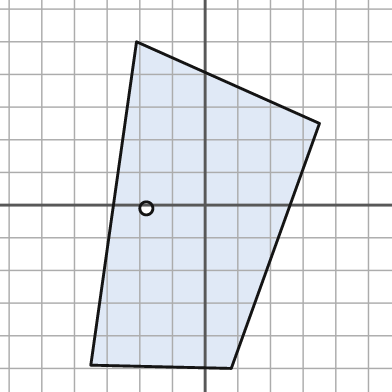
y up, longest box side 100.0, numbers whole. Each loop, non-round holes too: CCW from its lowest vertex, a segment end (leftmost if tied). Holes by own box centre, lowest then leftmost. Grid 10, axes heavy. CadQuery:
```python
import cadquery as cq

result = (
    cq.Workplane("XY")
    .moveTo(8.0, -50.0)
    .lineTo(35.0, 25.0)
    .lineTo(-21.0, 50.0)
    .lineTo(-35.0, -49.0)
    .close()
    .moveTo(-18.0, -1.0)
    .circle(2.0)
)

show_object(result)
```